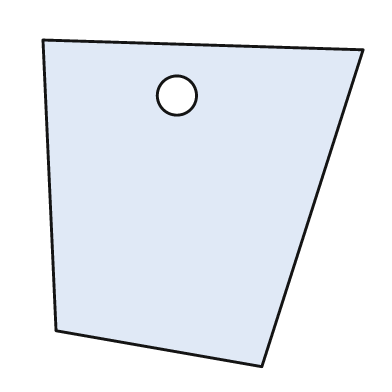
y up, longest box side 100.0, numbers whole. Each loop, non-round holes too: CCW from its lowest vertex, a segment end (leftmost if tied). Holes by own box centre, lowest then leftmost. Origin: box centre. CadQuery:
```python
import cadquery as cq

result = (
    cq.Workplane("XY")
    .moveTo(18.0, -50.0)
    .lineTo(49.0, 47.0)
    .lineTo(-49.0, 50.0)
    .lineTo(-45.0, -39.0)
    .close()
    .moveTo(-8.0, 33.0)
    .circle(6.0)
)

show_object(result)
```